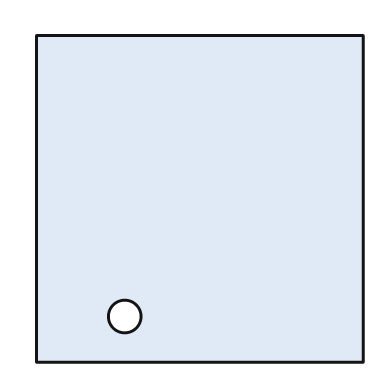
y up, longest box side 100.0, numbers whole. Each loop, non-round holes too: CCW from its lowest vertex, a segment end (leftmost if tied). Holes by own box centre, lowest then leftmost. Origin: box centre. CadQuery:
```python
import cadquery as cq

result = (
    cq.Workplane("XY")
    .moveTo(-50.0, -50.0)
    .lineTo(50.0, -50.0)
    .lineTo(50.0, 50.0)
    .lineTo(-50.0, 50.0)
    .close()
    .moveTo(-23.0, -36.0)
    .circle(5.0)
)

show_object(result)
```